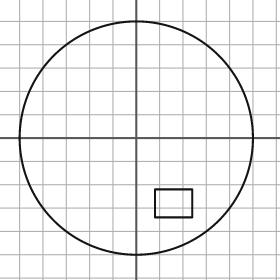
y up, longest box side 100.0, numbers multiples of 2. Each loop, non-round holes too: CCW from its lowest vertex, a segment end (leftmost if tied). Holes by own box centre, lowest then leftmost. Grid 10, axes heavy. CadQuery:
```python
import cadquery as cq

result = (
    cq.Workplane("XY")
    .moveTo(0.0, 0.0)
    .circle(50.0)
    .moveTo(8.0, -34.0)
    .lineTo(24.0, -34.0)
    .lineTo(24.0, -22.0)
    .lineTo(8.0, -22.0)
    .close()
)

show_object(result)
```